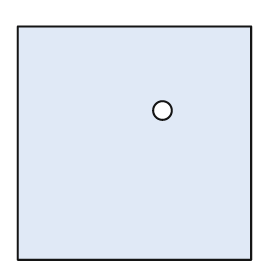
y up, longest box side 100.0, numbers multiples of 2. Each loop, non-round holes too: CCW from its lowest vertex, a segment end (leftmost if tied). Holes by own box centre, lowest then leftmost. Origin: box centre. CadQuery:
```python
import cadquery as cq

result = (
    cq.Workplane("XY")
    .moveTo(-50.0, -50.0)
    .lineTo(50.0, -50.0)
    .lineTo(50.0, 50.0)
    .lineTo(-50.0, 50.0)
    .close()
    .moveTo(12.0, 14.0)
    .circle(4.0)
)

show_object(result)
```